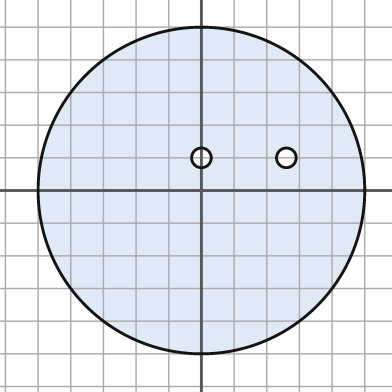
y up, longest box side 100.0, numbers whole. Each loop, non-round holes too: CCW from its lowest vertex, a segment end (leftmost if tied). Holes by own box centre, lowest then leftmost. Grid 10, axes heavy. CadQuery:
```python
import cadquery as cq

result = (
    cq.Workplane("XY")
    .moveTo(0.0, 0.0)
    .circle(50.0)
    .moveTo(0.0, 10.0)
    .circle(3.0)
    .moveTo(26.0, 10.0)
    .circle(3.0)
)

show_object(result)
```